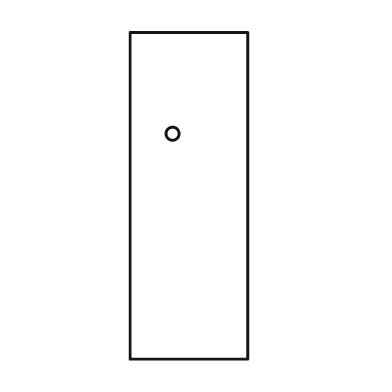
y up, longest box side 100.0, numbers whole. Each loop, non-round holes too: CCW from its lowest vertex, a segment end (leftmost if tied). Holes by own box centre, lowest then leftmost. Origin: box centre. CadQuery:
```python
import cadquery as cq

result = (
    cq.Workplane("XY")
    .moveTo(-18.0, -50.0)
    .lineTo(18.0, -50.0)
    .lineTo(18.0, 50.0)
    .lineTo(-18.0, 50.0)
    .close()
    .moveTo(-5.0, 19.0)
    .circle(2.0)
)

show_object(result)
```